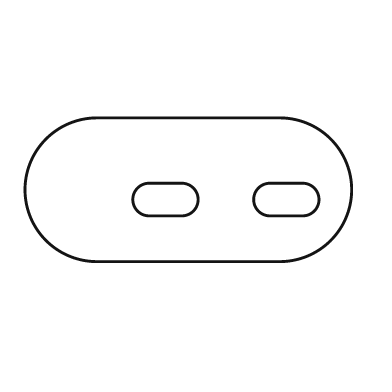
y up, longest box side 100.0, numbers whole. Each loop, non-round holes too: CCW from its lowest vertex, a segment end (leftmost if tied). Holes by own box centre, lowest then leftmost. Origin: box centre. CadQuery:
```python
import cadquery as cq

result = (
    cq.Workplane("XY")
    .moveTo(-28.0, -22.0)
    .lineTo(28.0, -22.0)
    .threePointArc((50.0, 0.0), (28.0, 22.0))
    .lineTo(-28.0, 22.0)
    .threePointArc((-50.0, 0.0), (-28.0, -22.0))
    .close()
    .moveTo(-12.0, -8.0)
    .lineTo(-2.0, -8.0)
    .threePointArc((3.0, -3.0), (-2.0, 2.0))
    .lineTo(-12.0, 2.0)
    .threePointArc((-17.0, -3.0), (-12.0, -8.0))
    .close()
    .moveTo(25.0, -8.0)
    .lineTo(35.0, -8.0)
    .threePointArc((40.0, -3.0), (35.0, 2.0))
    .lineTo(25.0, 2.0)
    .threePointArc((20.0, -3.0), (25.0, -8.0))
    .close()
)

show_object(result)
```